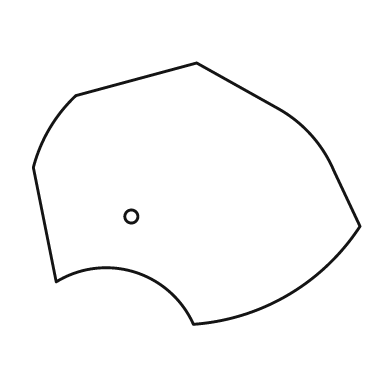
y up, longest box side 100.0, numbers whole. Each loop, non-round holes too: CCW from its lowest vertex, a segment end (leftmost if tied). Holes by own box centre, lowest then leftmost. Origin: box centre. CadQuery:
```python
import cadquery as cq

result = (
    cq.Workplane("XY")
    .moveTo(-1.0, -40.0)
    .threePointArc((28.0, -31.0), (50.0, -10.0))
    .lineTo(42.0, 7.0)
    .threePointArc((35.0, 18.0), (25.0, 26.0))
    .lineTo(0.0, 40.0)
    .lineTo(-37.0, 30.0)
    .threePointArc((-45.0, 20.0), (-50.0, 8.0))
    .lineTo(-43.0, -27.0)
    .threePointArc((-19.0, -24.0), (-1.0, -40.0))
    .close()
    .moveTo(-20.0, -7.0)
    .circle(2.0)
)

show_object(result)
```